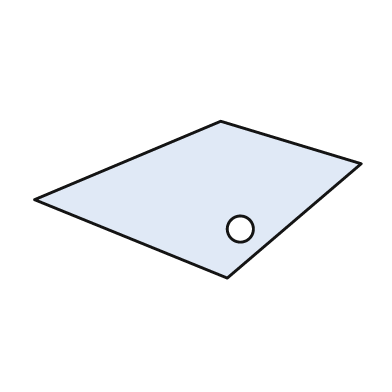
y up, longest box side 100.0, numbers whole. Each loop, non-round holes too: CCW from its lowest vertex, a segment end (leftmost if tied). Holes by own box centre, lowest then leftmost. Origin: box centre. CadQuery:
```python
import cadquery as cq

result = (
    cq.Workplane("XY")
    .moveTo(9.0, -24.0)
    .lineTo(50.0, 11.0)
    .lineTo(7.0, 24.0)
    .lineTo(-50.0, 0.0)
    .close()
    .moveTo(13.0, -9.0)
    .circle(4.0)
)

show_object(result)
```